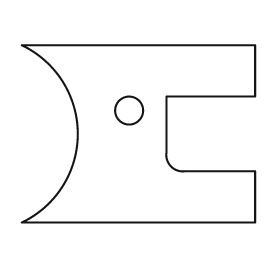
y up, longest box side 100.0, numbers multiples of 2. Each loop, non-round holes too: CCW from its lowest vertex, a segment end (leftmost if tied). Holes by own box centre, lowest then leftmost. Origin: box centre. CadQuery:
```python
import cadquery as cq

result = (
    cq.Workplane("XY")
    .moveTo(-50.0, -38.0)
    .lineTo(50.0, -38.0)
    .lineTo(50.0, -16.0)
    .lineTo(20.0, -16.0)
    .threePointArc((14.0, -14.0), (12.0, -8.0))
    .lineTo(12.0, 16.0)
    .lineTo(50.0, 16.0)
    .lineTo(50.0, 38.0)
    .lineTo(-50.0, 38.0)
    .threePointArc((-26.0, 0.0), (-50.0, -38.0))
    .close()
    .moveTo(-4.0, 10.0)
    .circle(6.0)
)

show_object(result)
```